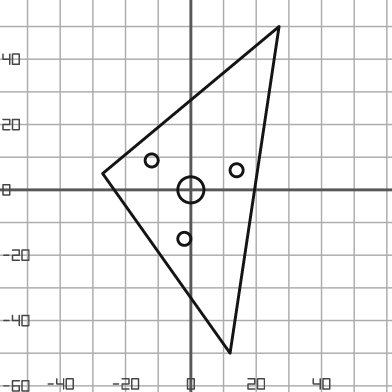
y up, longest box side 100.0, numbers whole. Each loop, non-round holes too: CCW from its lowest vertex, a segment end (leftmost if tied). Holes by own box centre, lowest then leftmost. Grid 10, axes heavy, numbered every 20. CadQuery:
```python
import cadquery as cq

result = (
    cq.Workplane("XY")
    .moveTo(12.0, -50.0)
    .lineTo(27.0, 50.0)
    .lineTo(-27.0, 5.0)
    .close()
    .moveTo(-2.0, -15.0)
    .circle(2.0)
    .moveTo(0.0, 0.0)
    .circle(4.0)
    .moveTo(14.0, 6.0)
    .circle(2.0)
    .moveTo(-12.0, 9.0)
    .circle(2.0)
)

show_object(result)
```